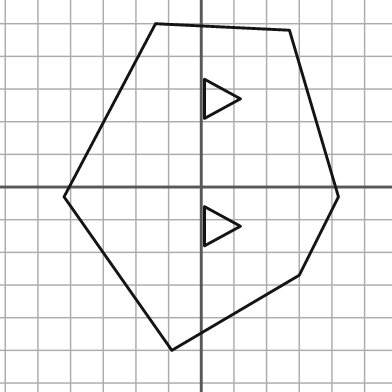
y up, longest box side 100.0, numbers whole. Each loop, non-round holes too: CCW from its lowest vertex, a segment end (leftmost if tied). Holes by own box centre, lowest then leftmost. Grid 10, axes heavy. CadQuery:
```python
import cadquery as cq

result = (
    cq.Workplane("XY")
    .moveTo(-9.0, -50.0)
    .lineTo(30.0, -27.0)
    .lineTo(42.0, -3.0)
    .lineTo(27.0, 48.0)
    .lineTo(-14.0, 50.0)
    .lineTo(-42.0, -3.0)
    .close()
    .moveTo(1.0, -18.0)
    .lineTo(12.0, -12.0)
    .lineTo(1.0, -6.0)
    .close()
    .moveTo(1.0, 21.0)
    .lineTo(12.0, 27.0)
    .lineTo(1.0, 33.0)
    .close()
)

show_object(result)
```